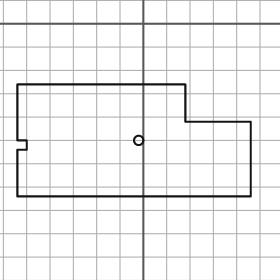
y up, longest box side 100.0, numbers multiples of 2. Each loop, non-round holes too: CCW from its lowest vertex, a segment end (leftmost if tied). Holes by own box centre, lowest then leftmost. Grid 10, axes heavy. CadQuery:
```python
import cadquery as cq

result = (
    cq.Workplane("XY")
    .moveTo(-54.0, -74.0)
    .lineTo(46.0, -74.0)
    .lineTo(46.0, -42.0)
    .lineTo(18.0, -42.0)
    .lineTo(18.0, -26.0)
    .lineTo(-54.0, -26.0)
    .lineTo(-54.0, -50.0)
    .lineTo(-50.0, -50.0)
    .lineTo(-50.0, -54.0)
    .lineTo(-54.0, -54.0)
    .close()
    .moveTo(-2.0, -50.0)
    .circle(2.0)
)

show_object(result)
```